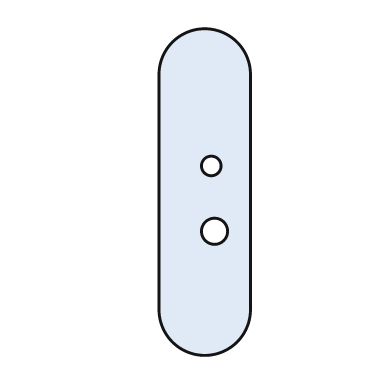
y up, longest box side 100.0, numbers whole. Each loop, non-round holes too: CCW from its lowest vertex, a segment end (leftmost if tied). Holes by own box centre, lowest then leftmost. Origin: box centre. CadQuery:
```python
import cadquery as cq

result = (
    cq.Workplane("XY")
    .moveTo(-14.0, -36.0)
    .threePointArc((0.0, -50.0), (14.0, -36.0))
    .lineTo(14.0, 36.0)
    .threePointArc((0.0, 50.0), (-14.0, 36.0))
    .close()
    .moveTo(3.0, -12.0)
    .circle(4.0)
    .moveTo(2.0, 8.0)
    .circle(3.0)
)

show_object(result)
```